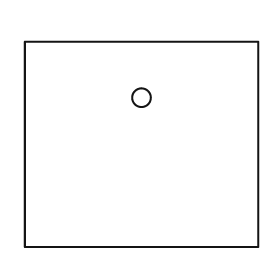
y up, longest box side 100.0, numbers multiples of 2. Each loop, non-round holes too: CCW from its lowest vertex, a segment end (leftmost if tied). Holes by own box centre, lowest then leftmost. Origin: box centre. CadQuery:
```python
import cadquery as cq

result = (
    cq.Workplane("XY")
    .moveTo(-50.0, -44.0)
    .lineTo(50.0, -44.0)
    .lineTo(50.0, 44.0)
    .lineTo(-50.0, 44.0)
    .close()
    .moveTo(0.0, 20.0)
    .circle(4.0)
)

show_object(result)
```